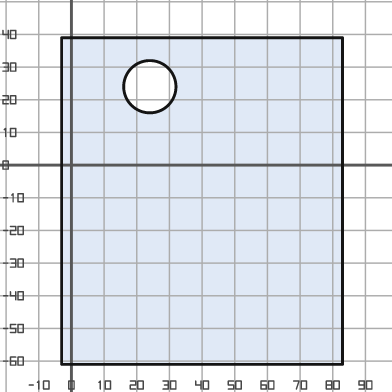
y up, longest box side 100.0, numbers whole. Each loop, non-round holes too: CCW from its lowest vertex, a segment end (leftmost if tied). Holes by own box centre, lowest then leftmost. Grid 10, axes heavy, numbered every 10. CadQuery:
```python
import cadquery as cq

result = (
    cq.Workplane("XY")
    .moveTo(-3.0, -61.0)
    .lineTo(83.0, -61.0)
    .lineTo(83.0, 39.0)
    .lineTo(-3.0, 39.0)
    .close()
    .moveTo(24.0, 24.0)
    .circle(8.0)
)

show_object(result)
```